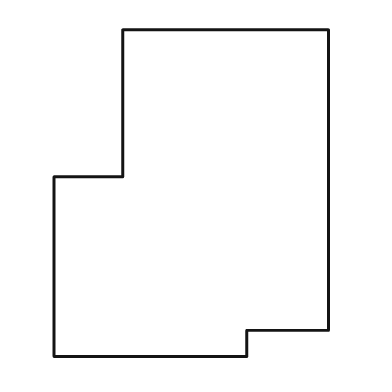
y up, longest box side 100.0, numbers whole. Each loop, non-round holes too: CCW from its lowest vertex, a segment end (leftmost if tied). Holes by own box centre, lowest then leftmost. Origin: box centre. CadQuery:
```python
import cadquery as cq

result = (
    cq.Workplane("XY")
    .moveTo(-42.0, -50.0)
    .lineTo(17.0, -50.0)
    .lineTo(17.0, -42.0)
    .lineTo(42.0, -42.0)
    .lineTo(42.0, 50.0)
    .lineTo(-21.0, 50.0)
    .lineTo(-21.0, 5.0)
    .lineTo(-42.0, 5.0)
    .close()
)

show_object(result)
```